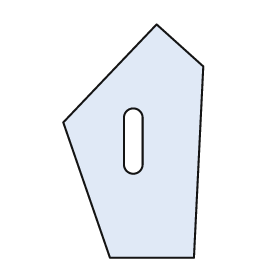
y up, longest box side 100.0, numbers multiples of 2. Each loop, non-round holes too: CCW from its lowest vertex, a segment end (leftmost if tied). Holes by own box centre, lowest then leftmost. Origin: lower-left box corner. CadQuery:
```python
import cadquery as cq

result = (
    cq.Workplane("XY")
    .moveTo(20.0, 0.0)
    .lineTo(56.0, 0.0)
    .lineTo(60.0, 82.0)
    .lineTo(40.0, 100.0)
    .lineTo(0.0, 58.0)
    .close()
    .moveTo(26.0, 40.0)
    .threePointArc((30.0, 36.0), (34.0, 40.0))
    .lineTo(34.0, 60.0)
    .threePointArc((30.0, 64.0), (26.0, 60.0))
    .close()
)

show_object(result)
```